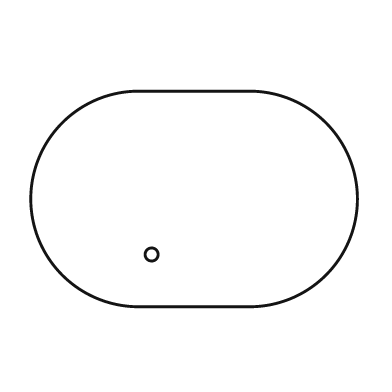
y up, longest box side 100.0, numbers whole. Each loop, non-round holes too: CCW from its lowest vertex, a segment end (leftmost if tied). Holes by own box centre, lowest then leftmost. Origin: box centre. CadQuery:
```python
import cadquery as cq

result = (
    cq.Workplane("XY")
    .moveTo(-17.0, -33.0)
    .lineTo(17.0, -33.0)
    .threePointArc((50.0, 0.0), (17.0, 33.0))
    .lineTo(-17.0, 33.0)
    .threePointArc((-50.0, 0.0), (-17.0, -33.0))
    .close()
    .moveTo(-13.0, -17.0)
    .circle(2.0)
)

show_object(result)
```